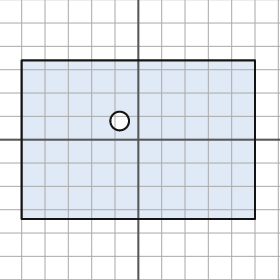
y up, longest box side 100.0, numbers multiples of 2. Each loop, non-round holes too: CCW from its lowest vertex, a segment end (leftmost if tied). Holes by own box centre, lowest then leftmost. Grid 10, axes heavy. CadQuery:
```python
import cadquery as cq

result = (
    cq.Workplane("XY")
    .moveTo(-50.0, -34.0)
    .lineTo(50.0, -34.0)
    .lineTo(50.0, 34.0)
    .lineTo(-50.0, 34.0)
    .close()
    .moveTo(-8.0, 8.0)
    .circle(4.0)
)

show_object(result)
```